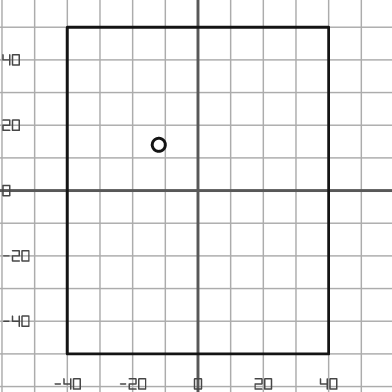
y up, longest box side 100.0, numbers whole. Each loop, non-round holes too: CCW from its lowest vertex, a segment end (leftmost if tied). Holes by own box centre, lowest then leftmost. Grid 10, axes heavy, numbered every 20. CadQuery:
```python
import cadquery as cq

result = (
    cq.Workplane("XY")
    .moveTo(-40.0, -50.0)
    .lineTo(40.0, -50.0)
    .lineTo(40.0, 50.0)
    .lineTo(-40.0, 50.0)
    .close()
    .moveTo(-12.0, 14.0)
    .circle(2.0)
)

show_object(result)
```